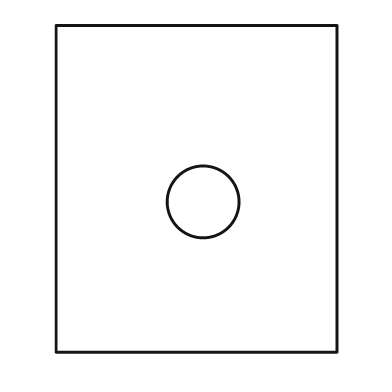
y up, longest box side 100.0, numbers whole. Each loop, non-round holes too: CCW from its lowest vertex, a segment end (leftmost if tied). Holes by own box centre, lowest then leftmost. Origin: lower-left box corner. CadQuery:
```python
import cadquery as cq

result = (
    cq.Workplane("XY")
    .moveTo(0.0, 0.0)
    .lineTo(86.0, 0.0)
    .lineTo(86.0, 100.0)
    .lineTo(0.0, 100.0)
    .close()
    .moveTo(45.0, 46.0)
    .circle(11.0)
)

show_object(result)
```